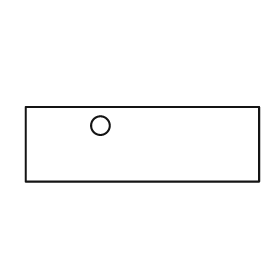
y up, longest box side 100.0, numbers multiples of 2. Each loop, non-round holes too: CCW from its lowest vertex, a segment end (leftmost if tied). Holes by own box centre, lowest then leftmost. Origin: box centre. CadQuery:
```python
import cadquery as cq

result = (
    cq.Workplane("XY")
    .moveTo(-50.0, -16.0)
    .lineTo(50.0, -16.0)
    .lineTo(50.0, 16.0)
    .lineTo(-50.0, 16.0)
    .close()
    .moveTo(-18.0, 8.0)
    .circle(4.0)
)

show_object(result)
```